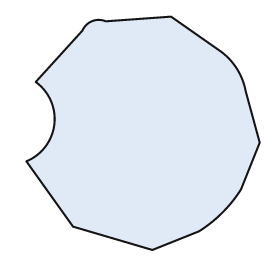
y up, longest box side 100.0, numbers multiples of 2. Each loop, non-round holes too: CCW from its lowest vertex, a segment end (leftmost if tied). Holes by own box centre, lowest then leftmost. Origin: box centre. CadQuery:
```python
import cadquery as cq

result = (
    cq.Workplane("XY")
    .moveTo(4.0, -50.0)
    .lineTo(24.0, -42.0)
    .threePointArc((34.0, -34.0), (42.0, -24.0))
    .lineTo(50.0, -4.0)
    .lineTo(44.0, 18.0)
    .threePointArc((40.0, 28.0), (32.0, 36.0))
    .lineTo(12.0, 50.0)
    .lineTo(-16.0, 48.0)
    .threePointArc((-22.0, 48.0), (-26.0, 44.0))
    .lineTo(-46.0, 22.0)
    .threePointArc((-38.0, 4.0), (-50.0, -12.0))
    .lineTo(-30.0, -40.0)
    .close()
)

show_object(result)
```